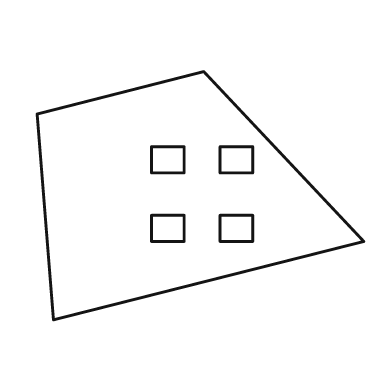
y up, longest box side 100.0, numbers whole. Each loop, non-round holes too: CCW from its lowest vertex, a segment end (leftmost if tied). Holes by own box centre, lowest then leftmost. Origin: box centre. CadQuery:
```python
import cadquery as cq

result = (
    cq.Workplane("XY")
    .moveTo(-45.0, -38.0)
    .lineTo(50.0, -14.0)
    .lineTo(1.0, 38.0)
    .lineTo(-50.0, 25.0)
    .close()
    .moveTo(-15.0, -14.0)
    .lineTo(-5.0, -14.0)
    .lineTo(-5.0, -6.0)
    .lineTo(-15.0, -6.0)
    .close()
    .moveTo(6.0, -14.0)
    .lineTo(16.0, -14.0)
    .lineTo(16.0, -6.0)
    .lineTo(6.0, -6.0)
    .close()
    .moveTo(-15.0, 7.0)
    .lineTo(-5.0, 7.0)
    .lineTo(-5.0, 15.0)
    .lineTo(-15.0, 15.0)
    .close()
    .moveTo(6.0, 7.0)
    .lineTo(16.0, 7.0)
    .lineTo(16.0, 15.0)
    .lineTo(6.0, 15.0)
    .close()
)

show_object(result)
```